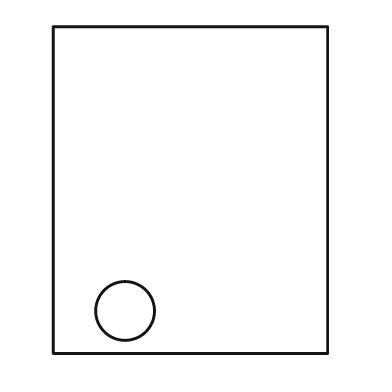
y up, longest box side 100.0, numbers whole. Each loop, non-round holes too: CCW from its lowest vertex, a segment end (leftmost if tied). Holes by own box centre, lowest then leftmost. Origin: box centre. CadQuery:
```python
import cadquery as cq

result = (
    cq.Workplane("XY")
    .moveTo(-42.0, -50.0)
    .lineTo(42.0, -50.0)
    .lineTo(42.0, 50.0)
    .lineTo(-42.0, 50.0)
    .close()
    .moveTo(-20.0, -37.0)
    .circle(9.0)
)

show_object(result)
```